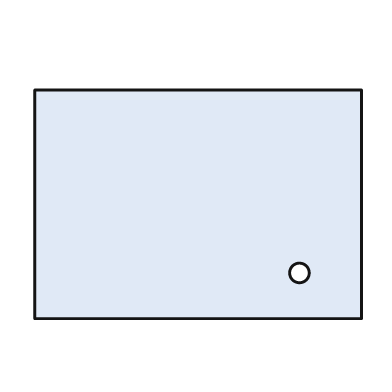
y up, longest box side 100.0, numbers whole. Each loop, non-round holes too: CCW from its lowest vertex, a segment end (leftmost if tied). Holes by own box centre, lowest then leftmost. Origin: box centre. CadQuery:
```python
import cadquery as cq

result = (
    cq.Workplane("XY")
    .moveTo(-50.0, -35.0)
    .lineTo(50.0, -35.0)
    .lineTo(50.0, 35.0)
    .lineTo(-50.0, 35.0)
    .close()
    .moveTo(31.0, -21.0)
    .circle(3.0)
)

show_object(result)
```